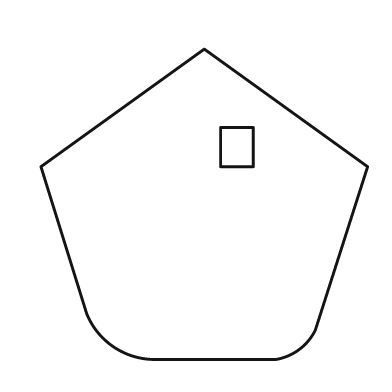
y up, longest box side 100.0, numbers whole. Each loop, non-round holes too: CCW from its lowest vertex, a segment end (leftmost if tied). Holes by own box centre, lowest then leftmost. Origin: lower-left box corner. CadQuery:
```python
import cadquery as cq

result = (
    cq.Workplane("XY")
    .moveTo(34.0, 0.0)
    .lineTo(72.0, 0.0)
    .threePointArc((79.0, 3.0), (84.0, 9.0))
    .lineTo(100.0, 59.0)
    .lineTo(50.0, 95.0)
    .lineTo(0.0, 59.0)
    .lineTo(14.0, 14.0)
    .threePointArc((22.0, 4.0), (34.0, 0.0))
    .close()
    .moveTo(55.0, 59.0)
    .lineTo(65.0, 59.0)
    .lineTo(65.0, 71.0)
    .lineTo(55.0, 71.0)
    .close()
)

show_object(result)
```